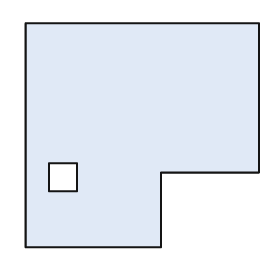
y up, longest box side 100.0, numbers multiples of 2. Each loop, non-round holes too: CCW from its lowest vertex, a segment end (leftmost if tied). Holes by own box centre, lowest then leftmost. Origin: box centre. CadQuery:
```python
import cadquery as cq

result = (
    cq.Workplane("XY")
    .moveTo(-50.0, -48.0)
    .lineTo(8.0, -48.0)
    .lineTo(8.0, -16.0)
    .lineTo(50.0, -16.0)
    .lineTo(50.0, 48.0)
    .lineTo(-50.0, 48.0)
    .close()
    .moveTo(-40.0, -24.0)
    .lineTo(-28.0, -24.0)
    .lineTo(-28.0, -12.0)
    .lineTo(-40.0, -12.0)
    .close()
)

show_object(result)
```